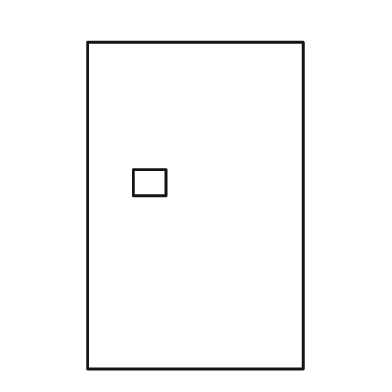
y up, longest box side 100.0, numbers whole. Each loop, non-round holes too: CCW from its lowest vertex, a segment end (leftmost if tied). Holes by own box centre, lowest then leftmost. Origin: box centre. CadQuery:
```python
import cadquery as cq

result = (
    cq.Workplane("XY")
    .moveTo(-33.0, -50.0)
    .lineTo(33.0, -50.0)
    .lineTo(33.0, 50.0)
    .lineTo(-33.0, 50.0)
    .close()
    .moveTo(-19.0, 3.0)
    .lineTo(-9.0, 3.0)
    .lineTo(-9.0, 11.0)
    .lineTo(-19.0, 11.0)
    .close()
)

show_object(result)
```